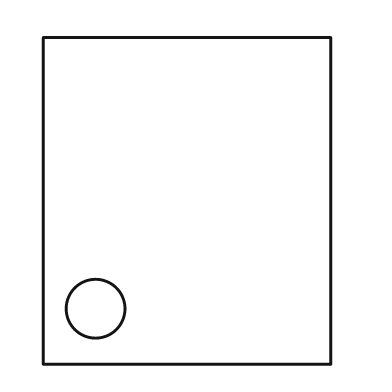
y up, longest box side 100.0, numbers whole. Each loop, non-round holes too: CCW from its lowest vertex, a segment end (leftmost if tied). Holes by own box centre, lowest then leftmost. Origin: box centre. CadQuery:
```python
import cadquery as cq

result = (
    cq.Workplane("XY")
    .moveTo(-44.0, -50.0)
    .lineTo(44.0, -50.0)
    .lineTo(44.0, 50.0)
    .lineTo(-44.0, 50.0)
    .close()
    .moveTo(-28.0, -33.0)
    .circle(9.0)
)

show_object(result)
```